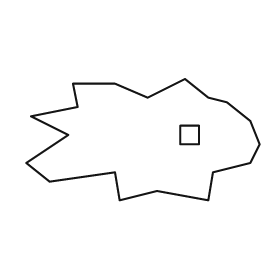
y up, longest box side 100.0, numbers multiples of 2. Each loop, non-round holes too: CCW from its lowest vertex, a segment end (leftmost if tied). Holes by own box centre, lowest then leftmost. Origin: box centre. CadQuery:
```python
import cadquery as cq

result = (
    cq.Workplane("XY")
    .moveTo(-10.0, -26.0)
    .lineTo(6.0, -22.0)
    .lineTo(28.0, -26.0)
    .lineTo(30.0, -14.0)
    .lineTo(46.0, -10.0)
    .lineTo(50.0, -2.0)
    .lineTo(46.0, 8.0)
    .lineTo(36.0, 16.0)
    .lineTo(28.0, 18.0)
    .lineTo(18.0, 26.0)
    .lineTo(2.0, 18.0)
    .lineTo(-12.0, 24.0)
    .lineTo(-30.0, 24.0)
    .lineTo(-28.0, 14.0)
    .lineTo(-48.0, 10.0)
    .lineTo(-32.0, 2.0)
    .lineTo(-50.0, -10.0)
    .lineTo(-40.0, -18.0)
    .lineTo(-12.0, -14.0)
    .close()
    .moveTo(16.0, -2.0)
    .lineTo(24.0, -2.0)
    .lineTo(24.0, 6.0)
    .lineTo(16.0, 6.0)
    .close()
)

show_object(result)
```